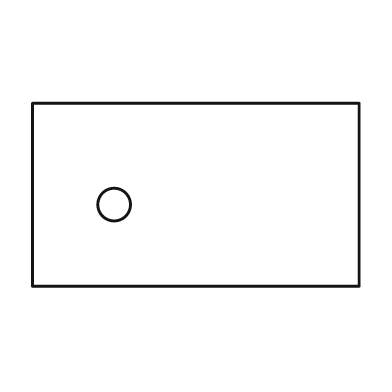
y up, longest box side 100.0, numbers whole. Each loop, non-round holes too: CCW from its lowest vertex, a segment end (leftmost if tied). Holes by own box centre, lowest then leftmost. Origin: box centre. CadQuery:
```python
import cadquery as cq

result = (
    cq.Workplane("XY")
    .moveTo(-50.0, -28.0)
    .lineTo(50.0, -28.0)
    .lineTo(50.0, 28.0)
    .lineTo(-50.0, 28.0)
    .close()
    .moveTo(-25.0, -3.0)
    .circle(5.0)
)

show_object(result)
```